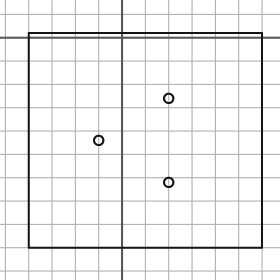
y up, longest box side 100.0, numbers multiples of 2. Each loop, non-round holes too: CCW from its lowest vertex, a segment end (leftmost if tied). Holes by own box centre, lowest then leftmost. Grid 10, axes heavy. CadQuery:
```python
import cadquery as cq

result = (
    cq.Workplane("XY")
    .moveTo(-40.0, -90.0)
    .lineTo(60.0, -90.0)
    .lineTo(60.0, 2.0)
    .lineTo(-40.0, 2.0)
    .close()
    .moveTo(20.0, -62.0)
    .circle(2.0)
    .moveTo(-10.0, -44.0)
    .circle(2.0)
    .moveTo(20.0, -26.0)
    .circle(2.0)
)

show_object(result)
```